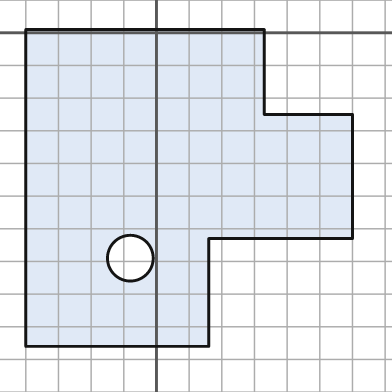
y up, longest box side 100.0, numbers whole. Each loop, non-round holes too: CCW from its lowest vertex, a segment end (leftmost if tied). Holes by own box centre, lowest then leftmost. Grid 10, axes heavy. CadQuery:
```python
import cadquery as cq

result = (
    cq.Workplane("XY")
    .moveTo(-40.0, -96.0)
    .lineTo(16.0, -96.0)
    .lineTo(16.0, -63.0)
    .lineTo(60.0, -63.0)
    .lineTo(60.0, -25.0)
    .lineTo(33.0, -25.0)
    .lineTo(33.0, 1.0)
    .lineTo(-40.0, 1.0)
    .close()
    .moveTo(-8.0, -69.0)
    .circle(7.0)
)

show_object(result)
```